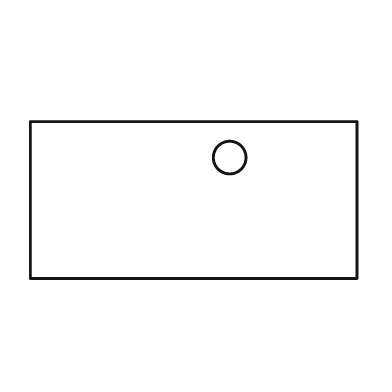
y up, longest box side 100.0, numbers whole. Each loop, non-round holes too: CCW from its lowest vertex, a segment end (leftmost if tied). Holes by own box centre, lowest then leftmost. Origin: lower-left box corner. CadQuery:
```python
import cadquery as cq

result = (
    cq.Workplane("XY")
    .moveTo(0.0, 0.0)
    .lineTo(100.0, 0.0)
    .lineTo(100.0, 48.0)
    .lineTo(0.0, 48.0)
    .close()
    .moveTo(61.0, 37.0)
    .circle(5.0)
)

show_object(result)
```